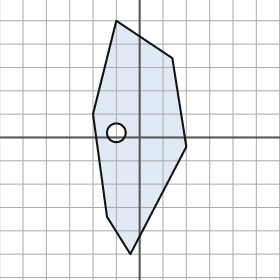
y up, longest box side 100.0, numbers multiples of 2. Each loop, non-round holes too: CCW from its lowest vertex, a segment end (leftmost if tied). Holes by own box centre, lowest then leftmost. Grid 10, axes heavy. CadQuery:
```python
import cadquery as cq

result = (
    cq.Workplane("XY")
    .moveTo(-4.0, -50.0)
    .lineTo(20.0, -4.0)
    .lineTo(14.0, 34.0)
    .lineTo(-10.0, 50.0)
    .lineTo(-20.0, 10.0)
    .lineTo(-14.0, -34.0)
    .close()
    .moveTo(-10.0, 2.0)
    .circle(4.0)
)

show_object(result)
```